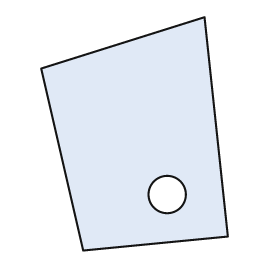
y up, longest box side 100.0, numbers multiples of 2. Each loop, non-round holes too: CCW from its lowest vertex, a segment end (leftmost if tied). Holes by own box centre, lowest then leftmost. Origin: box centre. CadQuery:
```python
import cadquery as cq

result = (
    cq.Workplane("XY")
    .moveTo(-22.0, -50.0)
    .lineTo(40.0, -44.0)
    .lineTo(30.0, 50.0)
    .lineTo(-40.0, 28.0)
    .close()
    .moveTo(14.0, -26.0)
    .circle(8.0)
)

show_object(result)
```